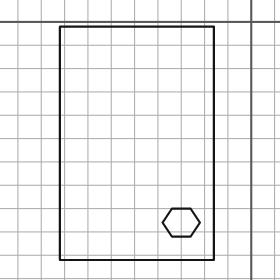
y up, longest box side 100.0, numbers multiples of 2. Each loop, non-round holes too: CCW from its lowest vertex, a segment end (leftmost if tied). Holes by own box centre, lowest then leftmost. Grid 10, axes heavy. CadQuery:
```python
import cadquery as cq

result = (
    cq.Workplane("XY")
    .moveTo(-82.0, -102.0)
    .lineTo(-16.0, -102.0)
    .lineTo(-16.0, -2.0)
    .lineTo(-82.0, -2.0)
    .close()
    .moveTo(-34.0, -92.0)
    .lineTo(-26.0, -92.0)
    .lineTo(-22.0, -86.0)
    .lineTo(-26.0, -80.0)
    .lineTo(-34.0, -80.0)
    .lineTo(-38.0, -86.0)
    .close()
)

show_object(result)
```